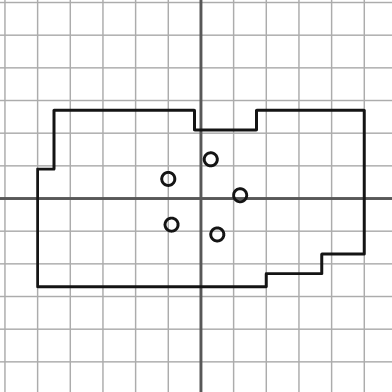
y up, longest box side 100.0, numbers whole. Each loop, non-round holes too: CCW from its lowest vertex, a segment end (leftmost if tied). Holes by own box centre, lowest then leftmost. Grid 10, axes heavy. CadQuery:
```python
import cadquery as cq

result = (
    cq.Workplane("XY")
    .moveTo(-50.0, -27.0)
    .lineTo(20.0, -27.0)
    .lineTo(20.0, -23.0)
    .lineTo(37.0, -23.0)
    .lineTo(37.0, -17.0)
    .lineTo(50.0, -17.0)
    .lineTo(50.0, 27.0)
    .lineTo(17.0, 27.0)
    .lineTo(17.0, 21.0)
    .lineTo(-2.0, 21.0)
    .lineTo(-2.0, 27.0)
    .lineTo(-45.0, 27.0)
    .lineTo(-45.0, 9.0)
    .lineTo(-50.0, 9.0)
    .close()
    .moveTo(5.0, -11.0)
    .circle(2.0)
    .moveTo(-9.0, -8.0)
    .circle(2.0)
    .moveTo(12.0, 1.0)
    .circle(2.0)
    .moveTo(-10.0, 6.0)
    .circle(2.0)
    .moveTo(3.0, 12.0)
    .circle(2.0)
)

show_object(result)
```